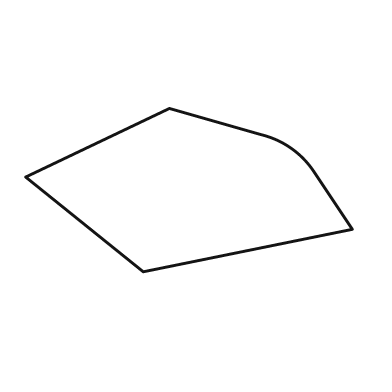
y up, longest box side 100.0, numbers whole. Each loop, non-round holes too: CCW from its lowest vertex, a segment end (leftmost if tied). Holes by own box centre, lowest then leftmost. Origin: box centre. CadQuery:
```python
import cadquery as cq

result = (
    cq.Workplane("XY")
    .moveTo(-14.0, -25.0)
    .lineTo(50.0, -12.0)
    .lineTo(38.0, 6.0)
    .threePointArc((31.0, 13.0), (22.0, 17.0))
    .lineTo(-6.0, 25.0)
    .lineTo(-50.0, 4.0)
    .close()
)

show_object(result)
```